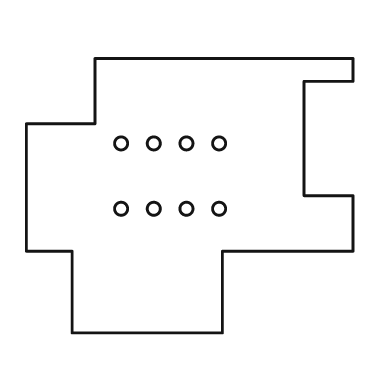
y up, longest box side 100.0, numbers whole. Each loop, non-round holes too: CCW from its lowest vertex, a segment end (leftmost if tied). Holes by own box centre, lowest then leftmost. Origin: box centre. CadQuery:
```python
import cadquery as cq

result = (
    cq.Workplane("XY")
    .moveTo(-36.0, -42.0)
    .lineTo(10.0, -42.0)
    .lineTo(10.0, -17.0)
    .lineTo(50.0, -17.0)
    .lineTo(50.0, 0.0)
    .lineTo(35.0, 0.0)
    .lineTo(35.0, 35.0)
    .lineTo(50.0, 35.0)
    .lineTo(50.0, 42.0)
    .lineTo(-29.0, 42.0)
    .lineTo(-29.0, 22.0)
    .lineTo(-50.0, 22.0)
    .lineTo(-50.0, -17.0)
    .lineTo(-36.0, -17.0)
    .close()
    .moveTo(-21.0, -4.0)
    .circle(2.0)
    .moveTo(-11.0, -4.0)
    .circle(2.0)
    .moveTo(-1.0, -4.0)
    .circle(2.0)
    .moveTo(9.0, -4.0)
    .circle(2.0)
    .moveTo(-21.0, 16.0)
    .circle(2.0)
    .moveTo(-11.0, 16.0)
    .circle(2.0)
    .moveTo(-1.0, 16.0)
    .circle(2.0)
    .moveTo(9.0, 16.0)
    .circle(2.0)
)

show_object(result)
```